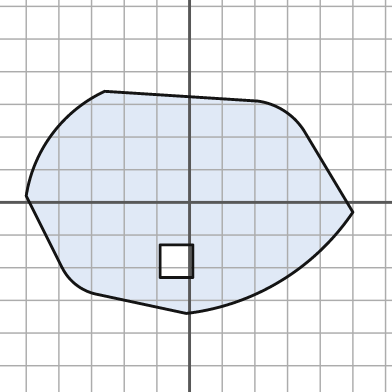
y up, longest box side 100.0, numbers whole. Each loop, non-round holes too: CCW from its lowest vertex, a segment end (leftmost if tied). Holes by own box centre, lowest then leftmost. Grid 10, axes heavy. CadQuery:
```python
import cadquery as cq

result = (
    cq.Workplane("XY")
    .moveTo(-1.0, -34.0)
    .threePointArc((28.0, -24.0), (50.0, -3.0))
    .lineTo(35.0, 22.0)
    .threePointArc((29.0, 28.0), (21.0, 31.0))
    .lineTo(-26.0, 34.0)
    .threePointArc((-42.0, 21.0), (-50.0, 2.0))
    .lineTo(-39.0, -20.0)
    .threePointArc((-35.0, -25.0), (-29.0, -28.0))
    .close()
    .moveTo(-9.0, -23.0)
    .lineTo(1.0, -23.0)
    .lineTo(1.0, -13.0)
    .lineTo(-9.0, -13.0)
    .close()
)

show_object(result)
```